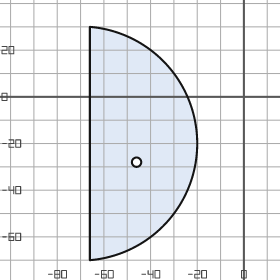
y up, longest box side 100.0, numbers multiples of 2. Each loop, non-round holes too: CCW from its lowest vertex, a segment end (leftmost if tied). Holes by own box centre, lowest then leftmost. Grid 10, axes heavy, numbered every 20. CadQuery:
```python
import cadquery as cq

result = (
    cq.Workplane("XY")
    .moveTo(-66.0, -70.0)
    .threePointArc((-20.0, -20.0), (-66.0, 30.0))
    .close()
    .moveTo(-46.0, -28.0)
    .circle(2.0)
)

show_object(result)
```